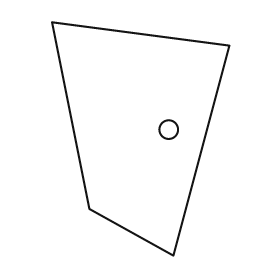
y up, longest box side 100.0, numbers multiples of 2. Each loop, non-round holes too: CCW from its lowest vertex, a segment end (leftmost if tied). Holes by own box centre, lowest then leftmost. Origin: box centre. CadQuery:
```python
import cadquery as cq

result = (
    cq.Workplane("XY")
    .moveTo(14.0, -50.0)
    .lineTo(38.0, 40.0)
    .lineTo(-38.0, 50.0)
    .lineTo(-22.0, -30.0)
    .close()
    .moveTo(12.0, 4.0)
    .circle(4.0)
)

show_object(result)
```